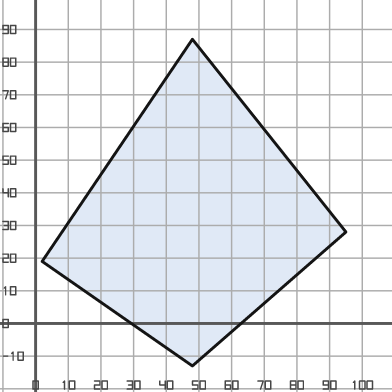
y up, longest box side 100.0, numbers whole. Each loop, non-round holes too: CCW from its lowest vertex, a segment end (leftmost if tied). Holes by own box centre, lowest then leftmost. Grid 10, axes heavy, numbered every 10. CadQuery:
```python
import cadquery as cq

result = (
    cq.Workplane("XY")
    .moveTo(48.0, -13.0)
    .lineTo(95.0, 28.0)
    .lineTo(48.0, 87.0)
    .lineTo(2.0, 19.0)
    .close()
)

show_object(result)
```